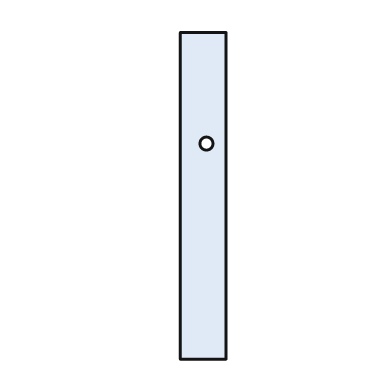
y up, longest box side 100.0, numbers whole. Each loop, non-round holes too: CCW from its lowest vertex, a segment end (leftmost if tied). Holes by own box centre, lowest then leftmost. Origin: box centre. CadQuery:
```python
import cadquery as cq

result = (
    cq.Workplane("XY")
    .moveTo(-7.0, -50.0)
    .lineTo(7.0, -50.0)
    .lineTo(7.0, 50.0)
    .lineTo(-7.0, 50.0)
    .close()
    .moveTo(1.0, 16.0)
    .circle(2.0)
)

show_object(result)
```